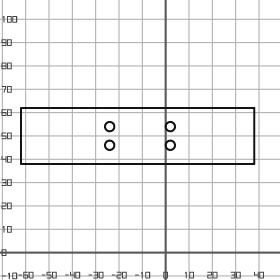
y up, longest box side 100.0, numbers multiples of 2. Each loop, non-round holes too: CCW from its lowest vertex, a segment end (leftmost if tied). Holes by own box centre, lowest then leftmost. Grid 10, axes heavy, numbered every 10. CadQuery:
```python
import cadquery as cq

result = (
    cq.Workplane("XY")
    .moveTo(-62.0, 38.0)
    .lineTo(38.0, 38.0)
    .lineTo(38.0, 62.0)
    .lineTo(-62.0, 62.0)
    .close()
    .moveTo(-24.0, 46.0)
    .circle(2.0)
    .moveTo(2.0, 46.0)
    .circle(2.0)
    .moveTo(-24.0, 54.0)
    .circle(2.0)
    .moveTo(2.0, 54.0)
    .circle(2.0)
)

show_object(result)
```